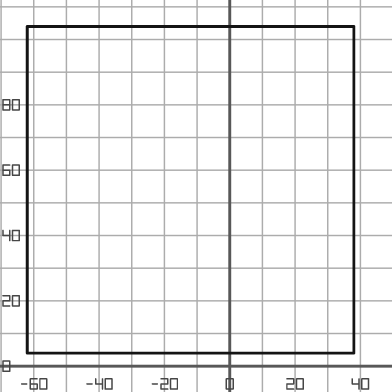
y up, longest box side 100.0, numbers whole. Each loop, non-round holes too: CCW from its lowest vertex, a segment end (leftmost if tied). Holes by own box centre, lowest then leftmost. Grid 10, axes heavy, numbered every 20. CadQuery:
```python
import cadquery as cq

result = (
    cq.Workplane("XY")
    .moveTo(-62.0, 4.0)
    .lineTo(38.0, 4.0)
    .lineTo(38.0, 104.0)
    .lineTo(-62.0, 104.0)
    .close()
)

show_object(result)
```